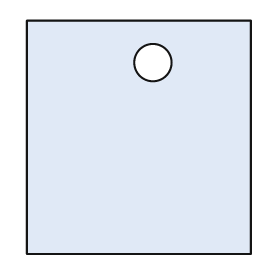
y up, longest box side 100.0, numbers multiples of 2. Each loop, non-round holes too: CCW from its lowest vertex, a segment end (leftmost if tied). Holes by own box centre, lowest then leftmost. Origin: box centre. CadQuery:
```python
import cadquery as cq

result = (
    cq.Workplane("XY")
    .moveTo(-48.0, -50.0)
    .lineTo(48.0, -50.0)
    .lineTo(48.0, 50.0)
    .lineTo(-48.0, 50.0)
    .close()
    .moveTo(6.0, 32.0)
    .circle(8.0)
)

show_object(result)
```